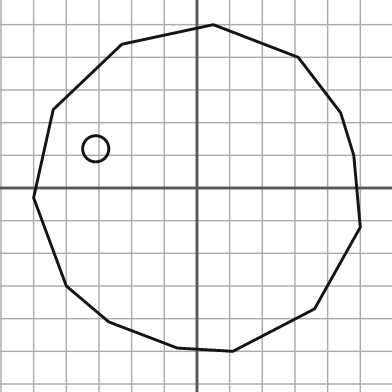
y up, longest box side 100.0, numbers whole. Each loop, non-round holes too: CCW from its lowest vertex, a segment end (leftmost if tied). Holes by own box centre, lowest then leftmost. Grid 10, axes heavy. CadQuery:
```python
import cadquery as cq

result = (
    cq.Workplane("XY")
    .moveTo(11.0, -50.0)
    .lineTo(36.0, -37.0)
    .lineTo(50.0, -12.0)
    .lineTo(48.0, 10.0)
    .lineTo(44.0, 23.0)
    .lineTo(31.0, 40.0)
    .lineTo(5.0, 50.0)
    .lineTo(-23.0, 44.0)
    .lineTo(-44.0, 24.0)
    .lineTo(-50.0, -3.0)
    .lineTo(-40.0, -30.0)
    .lineTo(-27.0, -41.0)
    .lineTo(-6.0, -49.0)
    .close()
    .moveTo(-31.0, 12.0)
    .circle(4.0)
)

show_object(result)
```